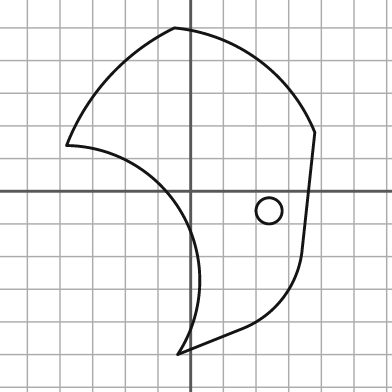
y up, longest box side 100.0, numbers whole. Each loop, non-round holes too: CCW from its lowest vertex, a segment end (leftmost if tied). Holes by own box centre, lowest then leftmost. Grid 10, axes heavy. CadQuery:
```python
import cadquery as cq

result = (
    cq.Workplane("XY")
    .moveTo(-4.0, -50.0)
    .lineTo(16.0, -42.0)
    .threePointArc((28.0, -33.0), (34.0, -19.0))
    .lineTo(38.0, 18.0)
    .threePointArc((21.0, 40.0), (-5.0, 50.0))
    .threePointArc((-25.0, 35.0), (-38.0, 14.0))
    .threePointArc((-2.0, -8.0), (-4.0, -50.0))
    .close()
    .moveTo(24.0, -6.0)
    .circle(4.0)
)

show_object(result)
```